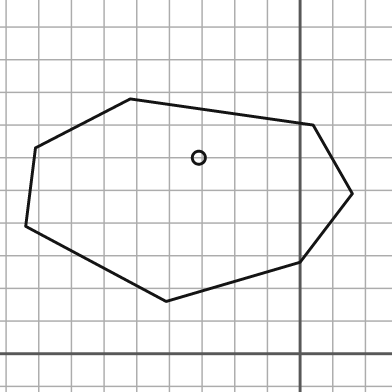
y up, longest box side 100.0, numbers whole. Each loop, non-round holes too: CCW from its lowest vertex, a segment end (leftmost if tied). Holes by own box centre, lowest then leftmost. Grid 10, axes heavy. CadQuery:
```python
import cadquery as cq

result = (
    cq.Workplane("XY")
    .moveTo(-41.0, 16.0)
    .lineTo(0.0, 28.0)
    .lineTo(16.0, 49.0)
    .lineTo(4.0, 70.0)
    .lineTo(-52.0, 78.0)
    .lineTo(-81.0, 63.0)
    .lineTo(-84.0, 39.0)
    .close()
    .moveTo(-31.0, 60.0)
    .circle(2.0)
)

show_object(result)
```